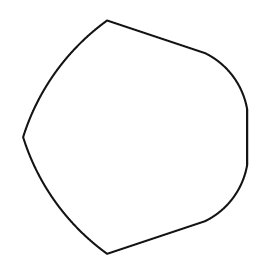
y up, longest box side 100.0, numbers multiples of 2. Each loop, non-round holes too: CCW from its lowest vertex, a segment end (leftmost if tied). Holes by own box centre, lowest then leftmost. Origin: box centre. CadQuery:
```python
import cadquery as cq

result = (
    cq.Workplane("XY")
    .moveTo(-12.0, -50.0)
    .lineTo(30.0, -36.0)
    .threePointArc((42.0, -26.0), (48.0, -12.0))
    .lineTo(48.0, 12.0)
    .threePointArc((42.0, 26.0), (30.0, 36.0))
    .lineTo(-12.0, 50.0)
    .threePointArc((-34.0, 28.0), (-48.0, 0.0))
    .threePointArc((-34.0, -28.0), (-12.0, -50.0))
    .close()
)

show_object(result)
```